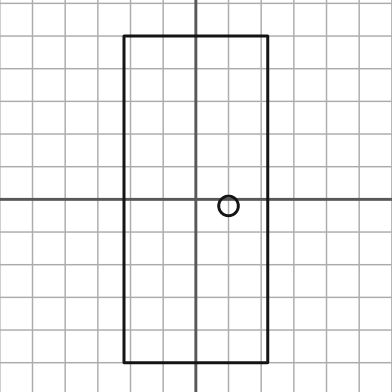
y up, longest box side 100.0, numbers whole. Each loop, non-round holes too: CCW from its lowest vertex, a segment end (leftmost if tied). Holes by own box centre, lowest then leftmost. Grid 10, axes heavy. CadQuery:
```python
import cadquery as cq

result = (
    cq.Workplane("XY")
    .moveTo(-22.0, -50.0)
    .lineTo(22.0, -50.0)
    .lineTo(22.0, 50.0)
    .lineTo(-22.0, 50.0)
    .close()
    .moveTo(10.0, -2.0)
    .circle(3.0)
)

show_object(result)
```